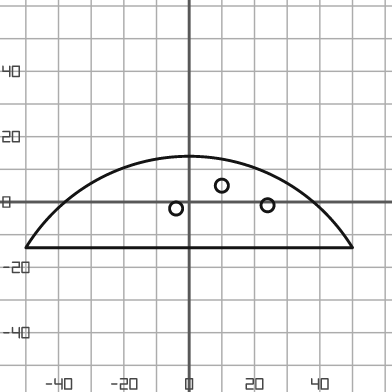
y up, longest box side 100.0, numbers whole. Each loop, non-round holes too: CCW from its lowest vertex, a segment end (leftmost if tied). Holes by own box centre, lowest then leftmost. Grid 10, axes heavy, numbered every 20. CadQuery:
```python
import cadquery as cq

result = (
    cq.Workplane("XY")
    .moveTo(-50.0, -14.0)
    .lineTo(50.0, -14.0)
    .threePointArc((0.0, 14.0), (-50.0, -14.0))
    .close()
    .moveTo(-4.0, -2.0)
    .circle(2.0)
    .moveTo(24.0, -1.0)
    .circle(2.0)
    .moveTo(10.0, 5.0)
    .circle(2.0)
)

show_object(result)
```